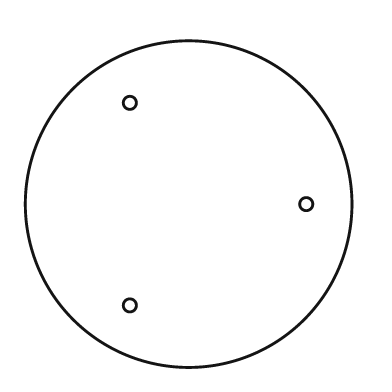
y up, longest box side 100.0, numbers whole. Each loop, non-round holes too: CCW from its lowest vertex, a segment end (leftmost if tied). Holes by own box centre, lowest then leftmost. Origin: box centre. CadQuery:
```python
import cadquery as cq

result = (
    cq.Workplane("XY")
    .moveTo(0.0, 0.0)
    .circle(50.0)
    .moveTo(-18.0, -31.0)
    .circle(2.0)
    .moveTo(36.0, 0.0)
    .circle(2.0)
    .moveTo(-18.0, 31.0)
    .circle(2.0)
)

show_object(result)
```